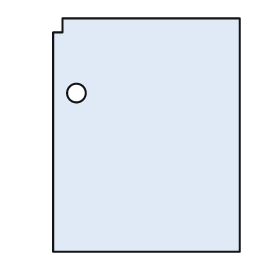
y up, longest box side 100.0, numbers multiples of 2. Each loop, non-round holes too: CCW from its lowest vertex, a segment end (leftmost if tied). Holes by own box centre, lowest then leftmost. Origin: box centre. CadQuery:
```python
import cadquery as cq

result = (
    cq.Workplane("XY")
    .moveTo(-40.0, -50.0)
    .lineTo(40.0, -50.0)
    .lineTo(40.0, 50.0)
    .lineTo(-36.0, 50.0)
    .lineTo(-36.0, 44.0)
    .lineTo(-40.0, 44.0)
    .close()
    .moveTo(-30.0, 18.0)
    .circle(4.0)
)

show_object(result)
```